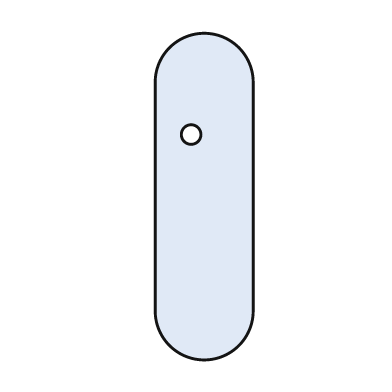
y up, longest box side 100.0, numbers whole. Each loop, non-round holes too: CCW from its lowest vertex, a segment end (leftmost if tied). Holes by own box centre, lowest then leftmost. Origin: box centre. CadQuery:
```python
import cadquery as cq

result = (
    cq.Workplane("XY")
    .moveTo(-15.0, -35.0)
    .threePointArc((0.0, -50.0), (15.0, -35.0))
    .lineTo(15.0, 35.0)
    .threePointArc((0.0, 50.0), (-15.0, 35.0))
    .close()
    .moveTo(-4.0, 19.0)
    .circle(3.0)
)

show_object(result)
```